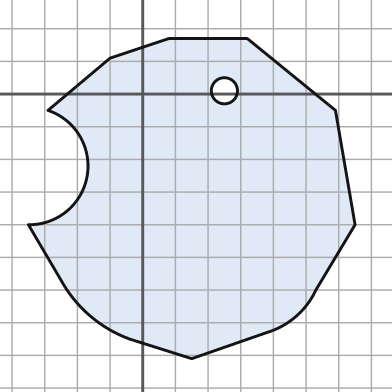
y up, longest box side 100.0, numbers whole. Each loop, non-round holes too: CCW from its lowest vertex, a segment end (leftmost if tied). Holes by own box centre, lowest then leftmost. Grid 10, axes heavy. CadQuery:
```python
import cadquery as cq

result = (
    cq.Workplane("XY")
    .moveTo(15.0, -81.0)
    .lineTo(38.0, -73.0)
    .threePointArc((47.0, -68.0), (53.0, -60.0))
    .lineTo(65.0, -40.0)
    .lineTo(59.0, -5.0)
    .lineTo(32.0, 17.0)
    .lineTo(8.0, 17.0)
    .lineTo(-10.0, 11.0)
    .lineTo(-29.0, -5.0)
    .threePointArc((-17.0, -25.0), (-35.0, -40.0))
    .lineTo(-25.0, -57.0)
    .threePointArc((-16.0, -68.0), (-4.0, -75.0))
    .close()
    .moveTo(25.0, 1.0)
    .circle(4.0)
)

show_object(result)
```